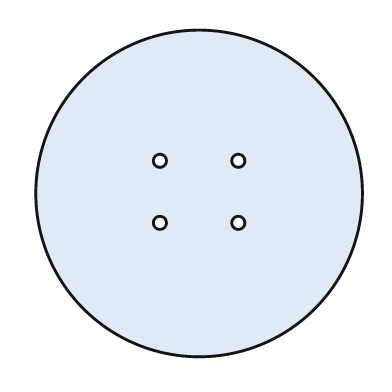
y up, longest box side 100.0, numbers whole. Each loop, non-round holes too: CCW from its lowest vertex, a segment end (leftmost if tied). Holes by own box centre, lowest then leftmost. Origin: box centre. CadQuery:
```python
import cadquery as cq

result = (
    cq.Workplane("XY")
    .moveTo(0.0, 0.0)
    .circle(50.0)
    .moveTo(-12.0, -9.0)
    .circle(2.0)
    .moveTo(12.0, -9.0)
    .circle(2.0)
    .moveTo(-12.0, 10.0)
    .circle(2.0)
    .moveTo(12.0, 10.0)
    .circle(2.0)
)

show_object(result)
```